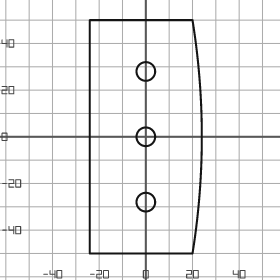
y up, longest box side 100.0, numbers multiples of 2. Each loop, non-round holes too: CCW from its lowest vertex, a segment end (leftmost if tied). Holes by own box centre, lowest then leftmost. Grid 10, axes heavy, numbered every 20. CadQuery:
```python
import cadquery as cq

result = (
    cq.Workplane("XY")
    .moveTo(-24.0, -50.0)
    .lineTo(20.0, -50.0)
    .threePointArc((24.0, 0.0), (20.0, 50.0))
    .lineTo(-24.0, 50.0)
    .close()
    .moveTo(0.0, -28.0)
    .circle(4.0)
    .moveTo(0.0, 0.0)
    .circle(4.0)
    .moveTo(0.0, 28.0)
    .circle(4.0)
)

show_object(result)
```